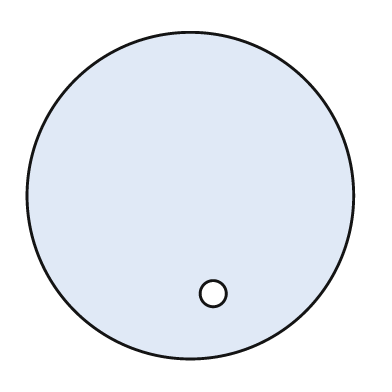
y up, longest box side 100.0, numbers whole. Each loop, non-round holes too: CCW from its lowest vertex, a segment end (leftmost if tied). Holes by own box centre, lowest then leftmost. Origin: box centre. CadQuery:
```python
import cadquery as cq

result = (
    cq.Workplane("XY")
    .moveTo(0.0, 0.0)
    .circle(50.0)
    .moveTo(7.0, -30.0)
    .circle(4.0)
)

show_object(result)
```